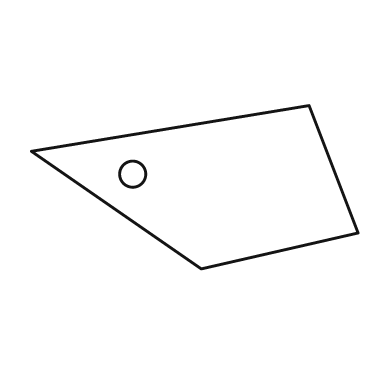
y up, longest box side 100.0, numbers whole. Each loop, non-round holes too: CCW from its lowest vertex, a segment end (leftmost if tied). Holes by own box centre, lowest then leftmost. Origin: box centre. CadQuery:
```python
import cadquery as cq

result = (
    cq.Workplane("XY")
    .moveTo(2.0, -25.0)
    .lineTo(50.0, -14.0)
    .lineTo(35.0, 25.0)
    .lineTo(-50.0, 11.0)
    .close()
    .moveTo(-19.0, 4.0)
    .circle(4.0)
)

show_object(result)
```